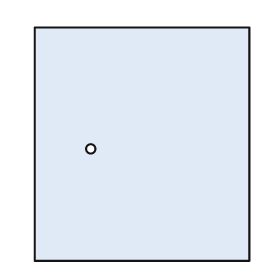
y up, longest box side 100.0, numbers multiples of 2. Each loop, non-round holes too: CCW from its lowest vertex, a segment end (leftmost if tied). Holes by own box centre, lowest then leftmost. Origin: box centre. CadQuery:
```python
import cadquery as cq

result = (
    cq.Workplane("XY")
    .moveTo(-46.0, -50.0)
    .lineTo(46.0, -50.0)
    .lineTo(46.0, 50.0)
    .lineTo(-46.0, 50.0)
    .close()
    .moveTo(-22.0, -2.0)
    .circle(2.0)
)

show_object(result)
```